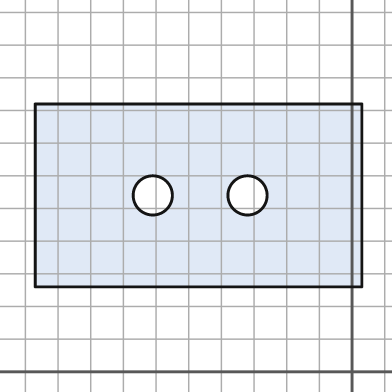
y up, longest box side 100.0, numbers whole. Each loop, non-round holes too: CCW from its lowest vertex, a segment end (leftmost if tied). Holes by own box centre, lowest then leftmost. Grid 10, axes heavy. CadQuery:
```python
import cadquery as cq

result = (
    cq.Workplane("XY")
    .moveTo(-97.0, 26.0)
    .lineTo(3.0, 26.0)
    .lineTo(3.0, 82.0)
    .lineTo(-97.0, 82.0)
    .close()
    .moveTo(-61.0, 54.0)
    .circle(6.0)
    .moveTo(-32.0, 54.0)
    .circle(6.0)
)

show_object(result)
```